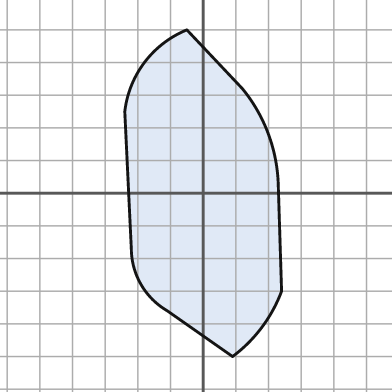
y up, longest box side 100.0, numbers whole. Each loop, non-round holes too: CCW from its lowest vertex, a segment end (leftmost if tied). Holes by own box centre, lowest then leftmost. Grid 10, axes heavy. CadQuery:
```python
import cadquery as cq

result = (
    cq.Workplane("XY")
    .moveTo(9.0, -50.0)
    .threePointArc((18.0, -41.0), (24.0, -30.0))
    .lineTo(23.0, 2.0)
    .threePointArc((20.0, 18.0), (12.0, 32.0))
    .lineTo(-5.0, 50.0)
    .threePointArc((-18.0, 40.0), (-24.0, 25.0))
    .lineTo(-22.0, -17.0)
    .threePointArc((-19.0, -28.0), (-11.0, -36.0))
    .close()
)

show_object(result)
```